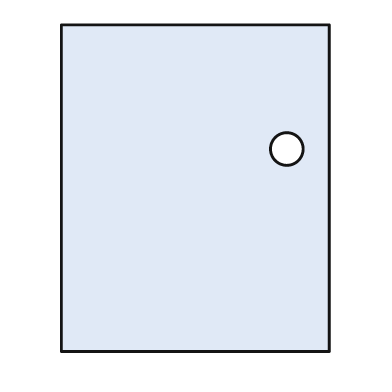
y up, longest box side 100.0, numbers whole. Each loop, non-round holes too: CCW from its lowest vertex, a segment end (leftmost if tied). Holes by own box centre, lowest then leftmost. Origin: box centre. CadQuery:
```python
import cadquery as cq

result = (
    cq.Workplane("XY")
    .moveTo(-41.0, -50.0)
    .lineTo(41.0, -50.0)
    .lineTo(41.0, 50.0)
    .lineTo(-41.0, 50.0)
    .close()
    .moveTo(28.0, 12.0)
    .circle(5.0)
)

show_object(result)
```